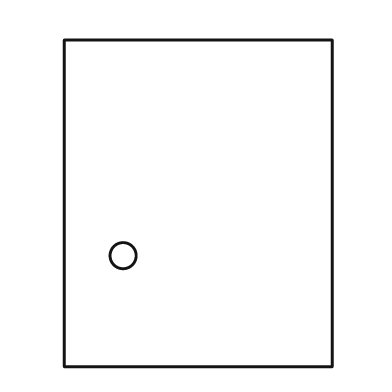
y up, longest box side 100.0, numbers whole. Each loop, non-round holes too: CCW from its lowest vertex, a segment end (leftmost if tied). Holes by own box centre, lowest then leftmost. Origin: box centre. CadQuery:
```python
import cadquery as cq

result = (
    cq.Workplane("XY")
    .moveTo(-41.0, -50.0)
    .lineTo(41.0, -50.0)
    .lineTo(41.0, 50.0)
    .lineTo(-41.0, 50.0)
    .close()
    .moveTo(-23.0, -16.0)
    .circle(4.0)
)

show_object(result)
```